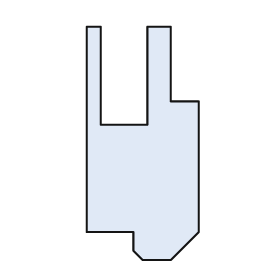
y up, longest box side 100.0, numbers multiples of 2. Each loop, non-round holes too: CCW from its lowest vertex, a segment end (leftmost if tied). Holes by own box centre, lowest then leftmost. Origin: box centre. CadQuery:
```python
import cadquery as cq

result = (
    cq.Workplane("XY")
    .moveTo(0.0, -50.0)
    .lineTo(12.0, -50.0)
    .lineTo(24.0, -38.0)
    .lineTo(24.0, 18.0)
    .lineTo(12.0, 18.0)
    .lineTo(12.0, 50.0)
    .lineTo(2.0, 50.0)
    .lineTo(2.0, 8.0)
    .lineTo(-18.0, 8.0)
    .lineTo(-18.0, 50.0)
    .lineTo(-24.0, 50.0)
    .lineTo(-24.0, -38.0)
    .lineTo(-4.0, -38.0)
    .lineTo(-4.0, -46.0)
    .close()
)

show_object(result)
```